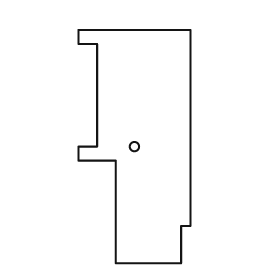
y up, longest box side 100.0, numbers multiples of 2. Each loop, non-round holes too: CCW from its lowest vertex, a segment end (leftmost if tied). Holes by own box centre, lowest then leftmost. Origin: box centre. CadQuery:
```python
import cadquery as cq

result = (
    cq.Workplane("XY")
    .moveTo(-8.0, -50.0)
    .lineTo(20.0, -50.0)
    .lineTo(20.0, -34.0)
    .lineTo(24.0, -34.0)
    .lineTo(24.0, 50.0)
    .lineTo(-24.0, 50.0)
    .lineTo(-24.0, 44.0)
    .lineTo(-16.0, 44.0)
    .lineTo(-16.0, 0.0)
    .lineTo(-24.0, 0.0)
    .lineTo(-24.0, -6.0)
    .lineTo(-8.0, -6.0)
    .close()
    .moveTo(0.0, 0.0)
    .circle(2.0)
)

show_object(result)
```